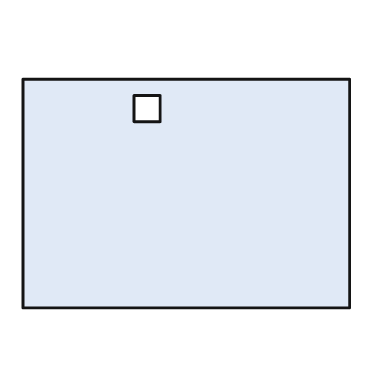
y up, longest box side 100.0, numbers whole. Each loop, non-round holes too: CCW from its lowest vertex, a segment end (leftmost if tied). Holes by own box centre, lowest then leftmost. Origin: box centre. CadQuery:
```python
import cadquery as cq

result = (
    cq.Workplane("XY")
    .moveTo(-50.0, -35.0)
    .lineTo(50.0, -35.0)
    .lineTo(50.0, 35.0)
    .lineTo(-50.0, 35.0)
    .close()
    .moveTo(-16.0, 22.0)
    .lineTo(-8.0, 22.0)
    .lineTo(-8.0, 30.0)
    .lineTo(-16.0, 30.0)
    .close()
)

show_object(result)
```